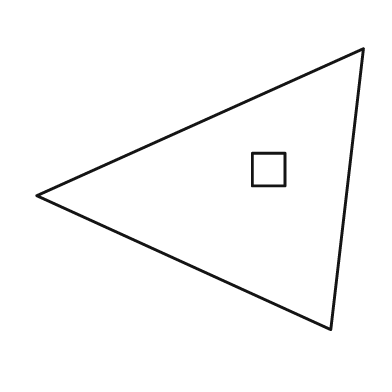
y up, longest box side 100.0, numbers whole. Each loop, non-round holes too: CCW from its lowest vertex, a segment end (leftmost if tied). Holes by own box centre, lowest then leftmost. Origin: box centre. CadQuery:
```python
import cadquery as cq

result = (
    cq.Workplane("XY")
    .moveTo(40.0, -43.0)
    .lineTo(50.0, 43.0)
    .lineTo(-50.0, -2.0)
    .close()
    .moveTo(16.0, 1.0)
    .lineTo(26.0, 1.0)
    .lineTo(26.0, 11.0)
    .lineTo(16.0, 11.0)
    .close()
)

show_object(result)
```